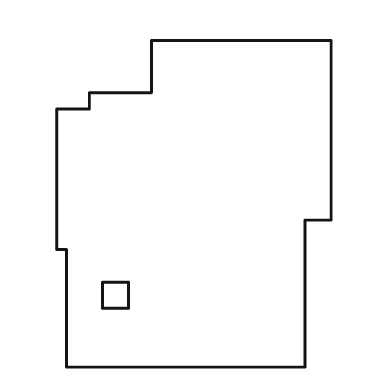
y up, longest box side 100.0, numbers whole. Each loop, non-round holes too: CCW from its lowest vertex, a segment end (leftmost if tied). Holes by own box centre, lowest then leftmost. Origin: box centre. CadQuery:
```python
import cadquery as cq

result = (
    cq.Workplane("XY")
    .moveTo(-39.0, -50.0)
    .lineTo(34.0, -50.0)
    .lineTo(34.0, -5.0)
    .lineTo(42.0, -5.0)
    .lineTo(42.0, 50.0)
    .lineTo(-13.0, 50.0)
    .lineTo(-13.0, 34.0)
    .lineTo(-32.0, 34.0)
    .lineTo(-32.0, 29.0)
    .lineTo(-42.0, 29.0)
    .lineTo(-42.0, -14.0)
    .lineTo(-39.0, -14.0)
    .close()
    .moveTo(-28.0, -32.0)
    .lineTo(-20.0, -32.0)
    .lineTo(-20.0, -24.0)
    .lineTo(-28.0, -24.0)
    .close()
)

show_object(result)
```